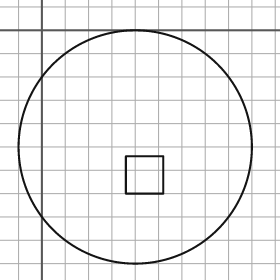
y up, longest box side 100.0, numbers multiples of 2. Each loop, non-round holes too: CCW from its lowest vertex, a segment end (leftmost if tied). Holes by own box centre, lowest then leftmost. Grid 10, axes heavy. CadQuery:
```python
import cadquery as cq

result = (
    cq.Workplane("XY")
    .moveTo(40.0, -50.0)
    .circle(50.0)
    .moveTo(36.0, -70.0)
    .lineTo(52.0, -70.0)
    .lineTo(52.0, -54.0)
    .lineTo(36.0, -54.0)
    .close()
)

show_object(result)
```